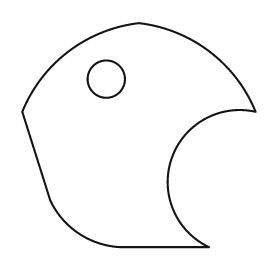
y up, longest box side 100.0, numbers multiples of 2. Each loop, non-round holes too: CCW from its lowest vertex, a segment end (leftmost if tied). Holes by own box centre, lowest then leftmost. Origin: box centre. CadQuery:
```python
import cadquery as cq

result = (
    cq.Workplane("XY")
    .moveTo(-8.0, -48.0)
    .lineTo(30.0, -48.0)
    .threePointArc((14.0, -10.0), (50.0, 10.0))
    .threePointArc((30.0, 36.0), (0.0, 48.0))
    .threePointArc((-30.0, 36.0), (-50.0, 10.0))
    .lineTo(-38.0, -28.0)
    .threePointArc((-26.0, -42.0), (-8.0, -48.0))
    .close()
    .moveTo(-14.0, 24.0)
    .circle(8.0)
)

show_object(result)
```